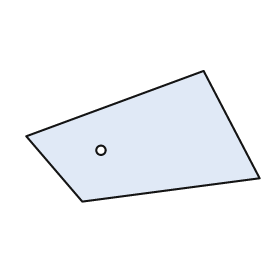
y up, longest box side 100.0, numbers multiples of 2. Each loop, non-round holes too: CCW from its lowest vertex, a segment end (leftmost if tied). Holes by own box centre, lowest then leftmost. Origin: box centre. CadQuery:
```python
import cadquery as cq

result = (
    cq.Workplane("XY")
    .moveTo(-26.0, -28.0)
    .lineTo(50.0, -18.0)
    .lineTo(26.0, 28.0)
    .lineTo(-50.0, 0.0)
    .close()
    .moveTo(-18.0, -6.0)
    .circle(2.0)
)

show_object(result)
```